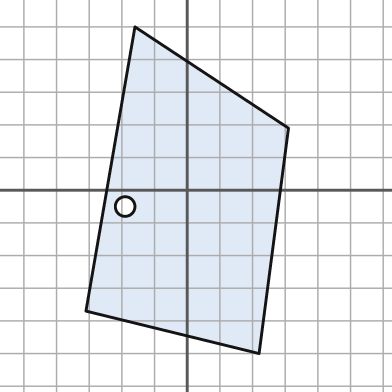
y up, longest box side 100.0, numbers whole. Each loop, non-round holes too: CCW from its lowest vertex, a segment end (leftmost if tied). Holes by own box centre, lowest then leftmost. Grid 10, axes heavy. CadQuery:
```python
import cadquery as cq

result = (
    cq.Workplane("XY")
    .moveTo(22.0, -50.0)
    .lineTo(31.0, 19.0)
    .lineTo(-16.0, 50.0)
    .lineTo(-31.0, -37.0)
    .close()
    .moveTo(-19.0, -5.0)
    .circle(3.0)
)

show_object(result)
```